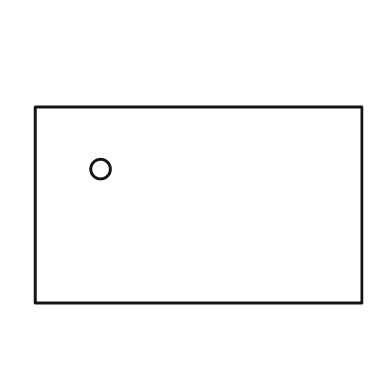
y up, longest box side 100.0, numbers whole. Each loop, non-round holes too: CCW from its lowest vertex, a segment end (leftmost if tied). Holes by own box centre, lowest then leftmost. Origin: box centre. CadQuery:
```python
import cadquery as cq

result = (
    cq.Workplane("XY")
    .moveTo(-50.0, -30.0)
    .lineTo(50.0, -30.0)
    .lineTo(50.0, 30.0)
    .lineTo(-50.0, 30.0)
    .close()
    .moveTo(-30.0, 11.0)
    .circle(3.0)
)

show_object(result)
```